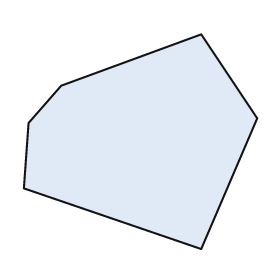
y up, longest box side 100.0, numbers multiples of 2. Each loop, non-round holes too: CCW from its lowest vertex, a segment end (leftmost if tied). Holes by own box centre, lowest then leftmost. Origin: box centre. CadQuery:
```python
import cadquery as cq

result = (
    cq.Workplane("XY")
    .moveTo(26.0, -46.0)
    .lineTo(50.0, 10.0)
    .lineTo(26.0, 46.0)
    .lineTo(-34.0, 24.0)
    .lineTo(-48.0, 8.0)
    .lineTo(-50.0, -20.0)
    .close()
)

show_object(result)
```